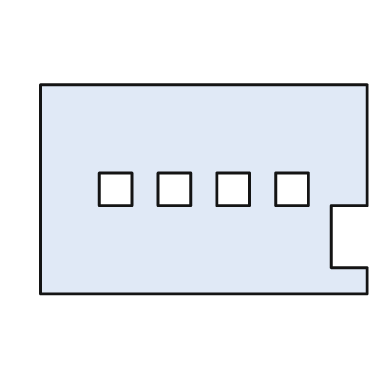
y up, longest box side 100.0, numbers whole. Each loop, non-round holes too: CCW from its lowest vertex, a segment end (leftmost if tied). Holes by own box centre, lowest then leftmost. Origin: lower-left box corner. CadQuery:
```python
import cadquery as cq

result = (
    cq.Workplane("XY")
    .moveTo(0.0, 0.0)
    .lineTo(100.0, 0.0)
    .lineTo(100.0, 8.0)
    .lineTo(89.0, 8.0)
    .lineTo(89.0, 27.0)
    .lineTo(100.0, 27.0)
    .lineTo(100.0, 64.0)
    .lineTo(0.0, 64.0)
    .close()
    .moveTo(18.0, 27.0)
    .lineTo(28.0, 27.0)
    .lineTo(28.0, 37.0)
    .lineTo(18.0, 37.0)
    .close()
    .moveTo(36.0, 27.0)
    .lineTo(46.0, 27.0)
    .lineTo(46.0, 37.0)
    .lineTo(36.0, 37.0)
    .close()
    .moveTo(54.0, 27.0)
    .lineTo(64.0, 27.0)
    .lineTo(64.0, 37.0)
    .lineTo(54.0, 37.0)
    .close()
    .moveTo(72.0, 27.0)
    .lineTo(82.0, 27.0)
    .lineTo(82.0, 37.0)
    .lineTo(72.0, 37.0)
    .close()
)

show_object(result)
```